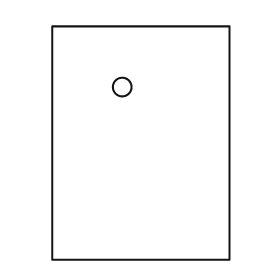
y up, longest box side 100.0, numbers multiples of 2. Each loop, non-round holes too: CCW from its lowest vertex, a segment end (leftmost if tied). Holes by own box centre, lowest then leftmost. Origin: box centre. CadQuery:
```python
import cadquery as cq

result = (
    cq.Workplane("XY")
    .moveTo(-38.0, -50.0)
    .lineTo(38.0, -50.0)
    .lineTo(38.0, 50.0)
    .lineTo(-38.0, 50.0)
    .close()
    .moveTo(-8.0, 24.0)
    .circle(4.0)
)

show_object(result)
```